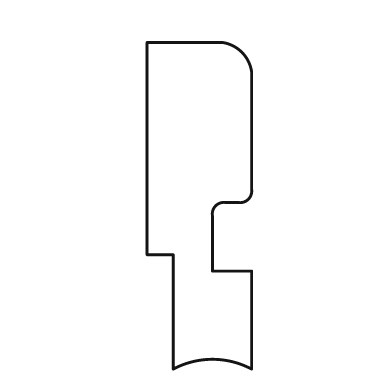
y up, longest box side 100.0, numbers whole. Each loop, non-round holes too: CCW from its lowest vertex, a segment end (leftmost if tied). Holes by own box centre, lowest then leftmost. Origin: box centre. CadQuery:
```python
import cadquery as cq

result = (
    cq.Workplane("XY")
    .moveTo(-8.0, -50.0)
    .threePointArc((4.0, -47.0), (16.0, -50.0))
    .lineTo(16.0, -20.0)
    .lineTo(4.0, -20.0)
    .lineTo(4.0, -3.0)
    .threePointArc((5.0, 0.0), (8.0, 1.0))
    .lineTo(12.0, 1.0)
    .threePointArc((15.0, 2.0), (16.0, 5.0))
    .lineTo(16.0, 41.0)
    .threePointArc((13.0, 47.0), (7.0, 50.0))
    .lineTo(-16.0, 50.0)
    .lineTo(-16.0, -15.0)
    .lineTo(-8.0, -15.0)
    .close()
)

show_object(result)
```